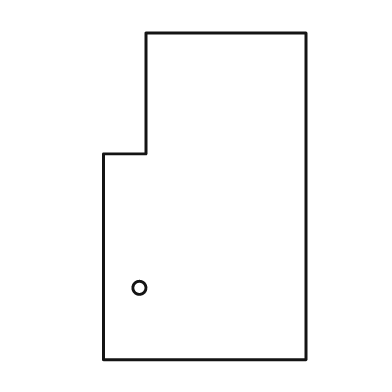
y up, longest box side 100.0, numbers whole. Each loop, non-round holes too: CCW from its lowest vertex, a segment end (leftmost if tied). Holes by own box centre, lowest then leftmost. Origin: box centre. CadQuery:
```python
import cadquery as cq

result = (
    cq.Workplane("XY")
    .moveTo(-31.0, -50.0)
    .lineTo(31.0, -50.0)
    .lineTo(31.0, 50.0)
    .lineTo(-18.0, 50.0)
    .lineTo(-18.0, 13.0)
    .lineTo(-31.0, 13.0)
    .close()
    .moveTo(-20.0, -28.0)
    .circle(2.0)
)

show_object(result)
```